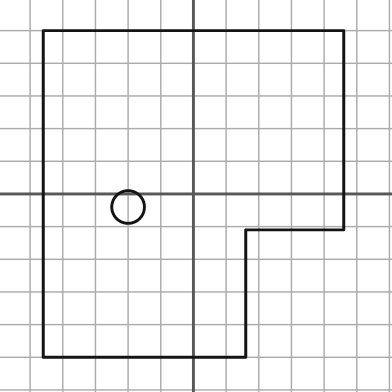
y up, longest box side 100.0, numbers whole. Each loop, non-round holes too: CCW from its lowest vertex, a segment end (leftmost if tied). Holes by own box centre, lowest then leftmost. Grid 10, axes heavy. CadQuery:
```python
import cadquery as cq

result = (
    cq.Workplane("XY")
    .moveTo(-46.0, -50.0)
    .lineTo(16.0, -50.0)
    .lineTo(16.0, -11.0)
    .lineTo(46.0, -11.0)
    .lineTo(46.0, 50.0)
    .lineTo(-46.0, 50.0)
    .close()
    .moveTo(-20.0, -4.0)
    .circle(5.0)
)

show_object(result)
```